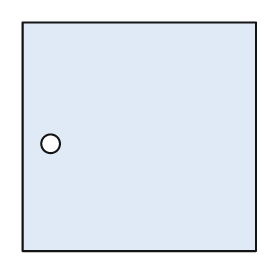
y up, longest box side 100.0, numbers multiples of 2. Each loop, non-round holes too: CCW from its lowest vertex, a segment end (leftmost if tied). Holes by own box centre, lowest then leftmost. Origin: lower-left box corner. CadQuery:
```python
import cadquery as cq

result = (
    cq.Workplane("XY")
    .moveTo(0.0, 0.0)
    .lineTo(100.0, 0.0)
    .lineTo(100.0, 98.0)
    .lineTo(0.0, 98.0)
    .close()
    .moveTo(12.0, 46.0)
    .circle(4.0)
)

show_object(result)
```